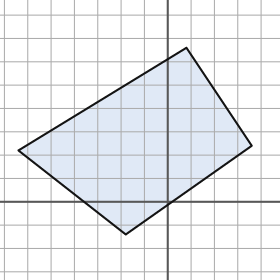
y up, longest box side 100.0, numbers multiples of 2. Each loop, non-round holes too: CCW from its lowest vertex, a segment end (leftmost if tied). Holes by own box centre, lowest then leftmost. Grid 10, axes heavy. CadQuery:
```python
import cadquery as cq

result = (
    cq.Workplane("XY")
    .moveTo(-18.0, -14.0)
    .lineTo(36.0, 24.0)
    .lineTo(8.0, 66.0)
    .lineTo(-64.0, 22.0)
    .close()
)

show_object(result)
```